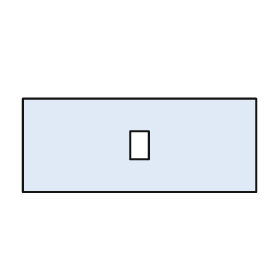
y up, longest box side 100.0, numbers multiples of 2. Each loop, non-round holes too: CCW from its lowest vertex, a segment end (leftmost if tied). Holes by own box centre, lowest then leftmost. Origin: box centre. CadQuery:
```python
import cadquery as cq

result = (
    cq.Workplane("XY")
    .moveTo(-50.0, -20.0)
    .lineTo(50.0, -20.0)
    .lineTo(50.0, 20.0)
    .lineTo(-50.0, 20.0)
    .close()
    .moveTo(-4.0, -6.0)
    .lineTo(4.0, -6.0)
    .lineTo(4.0, 6.0)
    .lineTo(-4.0, 6.0)
    .close()
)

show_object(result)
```